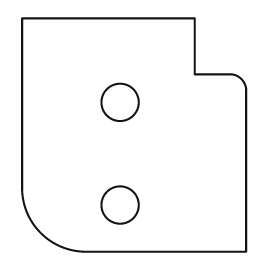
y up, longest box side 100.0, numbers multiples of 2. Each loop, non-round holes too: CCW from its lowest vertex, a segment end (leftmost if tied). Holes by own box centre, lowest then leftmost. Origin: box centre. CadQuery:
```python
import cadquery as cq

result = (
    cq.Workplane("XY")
    .moveTo(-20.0, -50.0)
    .lineTo(48.0, -50.0)
    .lineTo(48.0, 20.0)
    .threePointArc((46.0, 24.0), (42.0, 26.0))
    .lineTo(26.0, 26.0)
    .lineTo(26.0, 50.0)
    .lineTo(-48.0, 50.0)
    .lineTo(-48.0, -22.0)
    .threePointArc((-40.0, -42.0), (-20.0, -50.0))
    .close()
    .moveTo(-6.0, -30.0)
    .circle(8.0)
    .moveTo(-6.0, 14.0)
    .circle(8.0)
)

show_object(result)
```